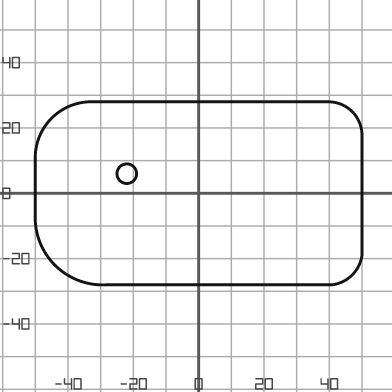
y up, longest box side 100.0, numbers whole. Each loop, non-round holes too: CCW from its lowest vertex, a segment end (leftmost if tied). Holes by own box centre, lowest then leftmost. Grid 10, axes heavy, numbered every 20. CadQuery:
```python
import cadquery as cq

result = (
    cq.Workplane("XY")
    .moveTo(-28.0, -28.0)
    .lineTo(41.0, -28.0)
    .threePointArc((47.0, -25.0), (50.0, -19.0))
    .lineTo(50.0, 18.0)
    .threePointArc((47.0, 25.0), (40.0, 28.0))
    .lineTo(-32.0, 28.0)
    .threePointArc((-45.0, 23.0), (-50.0, 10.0))
    .lineTo(-50.0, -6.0)
    .threePointArc((-44.0, -22.0), (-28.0, -28.0))
    .close()
    .moveTo(-22.0, 6.0)
    .circle(3.0)
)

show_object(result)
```